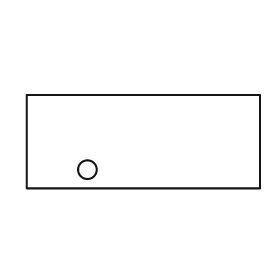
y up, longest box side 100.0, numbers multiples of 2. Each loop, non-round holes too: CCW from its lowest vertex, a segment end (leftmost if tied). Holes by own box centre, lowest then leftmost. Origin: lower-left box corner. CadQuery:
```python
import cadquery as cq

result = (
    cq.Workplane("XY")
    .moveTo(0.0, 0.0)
    .lineTo(100.0, 0.0)
    .lineTo(100.0, 40.0)
    .lineTo(0.0, 40.0)
    .close()
    .moveTo(26.0, 8.0)
    .circle(4.0)
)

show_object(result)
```